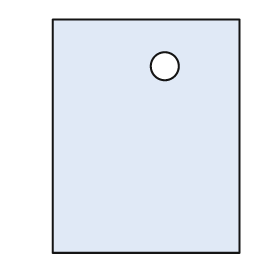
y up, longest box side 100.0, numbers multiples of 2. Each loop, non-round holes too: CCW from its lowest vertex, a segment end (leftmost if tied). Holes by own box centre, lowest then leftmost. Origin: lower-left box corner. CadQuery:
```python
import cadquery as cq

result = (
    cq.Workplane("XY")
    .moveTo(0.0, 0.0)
    .lineTo(80.0, 0.0)
    .lineTo(80.0, 100.0)
    .lineTo(0.0, 100.0)
    .close()
    .moveTo(48.0, 80.0)
    .circle(6.0)
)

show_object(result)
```